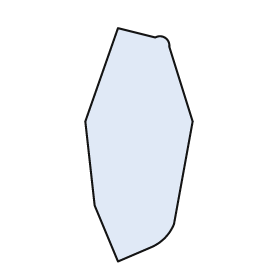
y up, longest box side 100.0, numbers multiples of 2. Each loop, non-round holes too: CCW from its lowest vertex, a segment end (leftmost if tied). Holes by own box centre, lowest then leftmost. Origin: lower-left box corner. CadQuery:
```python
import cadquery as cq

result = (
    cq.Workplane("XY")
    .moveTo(14.0, 0.0)
    .lineTo(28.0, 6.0)
    .threePointArc((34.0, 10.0), (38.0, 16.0))
    .lineTo(46.0, 60.0)
    .lineTo(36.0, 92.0)
    .threePointArc((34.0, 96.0), (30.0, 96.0))
    .lineTo(14.0, 100.0)
    .lineTo(0.0, 60.0)
    .lineTo(4.0, 24.0)
    .close()
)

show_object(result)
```